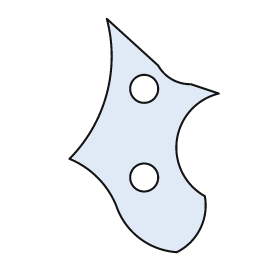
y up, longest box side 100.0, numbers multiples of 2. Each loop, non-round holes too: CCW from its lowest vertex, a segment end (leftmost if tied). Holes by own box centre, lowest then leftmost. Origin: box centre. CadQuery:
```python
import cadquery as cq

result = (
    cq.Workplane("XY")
    .moveTo(14.0, -50.0)
    .threePointArc((24.0, -40.0), (26.0, -26.0))
    .threePointArc((14.0, -2.0), (32.0, 18.0))
    .lineTo(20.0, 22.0)
    .threePointArc((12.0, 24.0), (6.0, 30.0))
    .lineTo(-16.0, 50.0)
    .threePointArc((-16.0, 18.0), (-32.0, -10.0))
    .threePointArc((-20.0, -18.0), (-12.0, -30.0))
    .threePointArc((-2.0, -44.0), (14.0, -50.0))
    .close()
    .moveTo(0.0, -18.0)
    .circle(6.0)
    .moveTo(0.0, 20.0)
    .circle(6.0)
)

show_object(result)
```